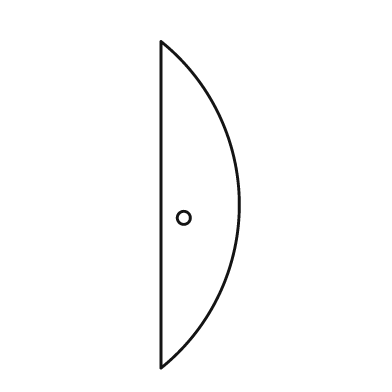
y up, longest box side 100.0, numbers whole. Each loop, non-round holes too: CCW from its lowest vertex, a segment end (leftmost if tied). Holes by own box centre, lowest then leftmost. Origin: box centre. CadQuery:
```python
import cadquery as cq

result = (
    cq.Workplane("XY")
    .moveTo(-12.0, -50.0)
    .threePointArc((12.0, 0.0), (-12.0, 50.0))
    .close()
    .moveTo(-5.0, -4.0)
    .circle(2.0)
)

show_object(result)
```